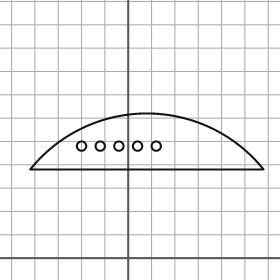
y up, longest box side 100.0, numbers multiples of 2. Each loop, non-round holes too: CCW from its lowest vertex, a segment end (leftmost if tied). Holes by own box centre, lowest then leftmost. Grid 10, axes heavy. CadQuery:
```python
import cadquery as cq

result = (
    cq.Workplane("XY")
    .moveTo(-42.0, 38.0)
    .lineTo(58.0, 38.0)
    .threePointArc((8.0, 62.0), (-42.0, 38.0))
    .close()
    .moveTo(-20.0, 48.0)
    .circle(2.0)
    .moveTo(-12.0, 48.0)
    .circle(2.0)
    .moveTo(-4.0, 48.0)
    .circle(2.0)
    .moveTo(4.0, 48.0)
    .circle(2.0)
    .moveTo(12.0, 48.0)
    .circle(2.0)
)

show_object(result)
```